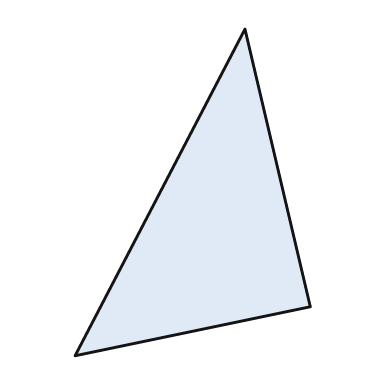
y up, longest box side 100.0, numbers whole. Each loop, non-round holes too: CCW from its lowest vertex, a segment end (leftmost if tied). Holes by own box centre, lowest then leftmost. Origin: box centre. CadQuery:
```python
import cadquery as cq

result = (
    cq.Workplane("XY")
    .moveTo(-36.0, -50.0)
    .lineTo(36.0, -35.0)
    .lineTo(16.0, 50.0)
    .close()
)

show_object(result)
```